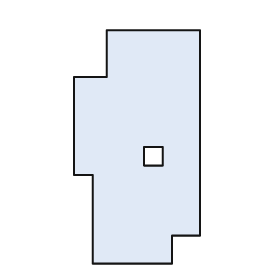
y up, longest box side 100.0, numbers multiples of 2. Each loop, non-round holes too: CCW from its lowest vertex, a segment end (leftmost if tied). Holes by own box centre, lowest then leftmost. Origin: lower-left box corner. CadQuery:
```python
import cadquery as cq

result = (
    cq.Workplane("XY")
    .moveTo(8.0, 0.0)
    .lineTo(42.0, 0.0)
    .lineTo(42.0, 12.0)
    .lineTo(54.0, 12.0)
    .lineTo(54.0, 100.0)
    .lineTo(14.0, 100.0)
    .lineTo(14.0, 80.0)
    .lineTo(0.0, 80.0)
    .lineTo(0.0, 38.0)
    .lineTo(8.0, 38.0)
    .close()
    .moveTo(30.0, 42.0)
    .lineTo(38.0, 42.0)
    .lineTo(38.0, 50.0)
    .lineTo(30.0, 50.0)
    .close()
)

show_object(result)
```